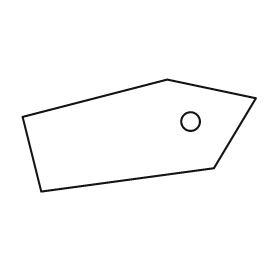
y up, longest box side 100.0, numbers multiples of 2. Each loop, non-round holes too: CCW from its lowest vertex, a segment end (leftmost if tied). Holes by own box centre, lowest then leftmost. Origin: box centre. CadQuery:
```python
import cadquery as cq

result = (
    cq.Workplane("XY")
    .moveTo(-42.0, -24.0)
    .lineTo(32.0, -14.0)
    .lineTo(50.0, 16.0)
    .lineTo(12.0, 24.0)
    .lineTo(-50.0, 8.0)
    .close()
    .moveTo(22.0, 6.0)
    .circle(4.0)
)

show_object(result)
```